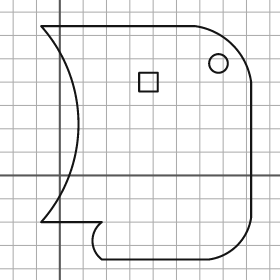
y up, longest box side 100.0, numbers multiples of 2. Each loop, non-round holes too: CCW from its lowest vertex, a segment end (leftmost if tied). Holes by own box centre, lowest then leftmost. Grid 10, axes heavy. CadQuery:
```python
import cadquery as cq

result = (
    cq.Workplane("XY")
    .moveTo(18.0, -36.0)
    .lineTo(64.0, -36.0)
    .threePointArc((76.0, -30.0), (82.0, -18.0))
    .lineTo(82.0, 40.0)
    .threePointArc((74.0, 56.0), (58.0, 64.0))
    .lineTo(-8.0, 64.0)
    .threePointArc((8.0, 22.0), (-8.0, -20.0))
    .lineTo(18.0, -20.0)
    .threePointArc((14.0, -28.0), (18.0, -36.0))
    .close()
    .moveTo(34.0, 36.0)
    .lineTo(42.0, 36.0)
    .lineTo(42.0, 44.0)
    .lineTo(34.0, 44.0)
    .close()
    .moveTo(68.0, 48.0)
    .circle(4.0)
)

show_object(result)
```